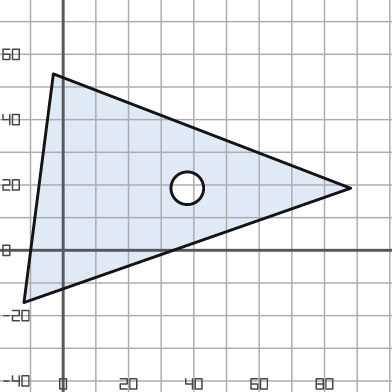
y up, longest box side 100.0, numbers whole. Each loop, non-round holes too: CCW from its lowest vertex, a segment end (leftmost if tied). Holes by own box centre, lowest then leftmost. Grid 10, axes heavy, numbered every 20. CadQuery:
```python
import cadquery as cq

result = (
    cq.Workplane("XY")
    .moveTo(-12.0, -16.0)
    .lineTo(88.0, 19.0)
    .lineTo(-3.0, 54.0)
    .close()
    .moveTo(38.0, 19.0)
    .circle(5.0)
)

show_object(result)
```